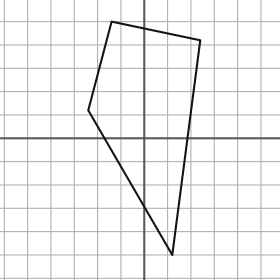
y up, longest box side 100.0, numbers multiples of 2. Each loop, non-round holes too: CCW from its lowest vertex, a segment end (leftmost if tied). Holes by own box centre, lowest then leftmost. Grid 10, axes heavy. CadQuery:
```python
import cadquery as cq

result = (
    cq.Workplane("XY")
    .moveTo(12.0, -50.0)
    .lineTo(24.0, 42.0)
    .lineTo(-14.0, 50.0)
    .lineTo(-24.0, 12.0)
    .close()
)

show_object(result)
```